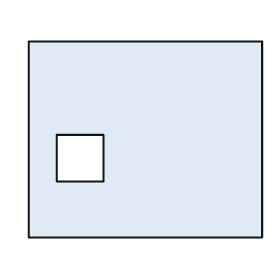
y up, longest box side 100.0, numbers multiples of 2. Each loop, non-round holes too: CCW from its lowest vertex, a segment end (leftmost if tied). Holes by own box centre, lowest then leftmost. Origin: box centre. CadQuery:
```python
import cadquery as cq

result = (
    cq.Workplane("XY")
    .moveTo(-50.0, -42.0)
    .lineTo(50.0, -42.0)
    .lineTo(50.0, 42.0)
    .lineTo(-50.0, 42.0)
    .close()
    .moveTo(-38.0, -18.0)
    .lineTo(-18.0, -18.0)
    .lineTo(-18.0, 2.0)
    .lineTo(-38.0, 2.0)
    .close()
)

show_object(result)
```